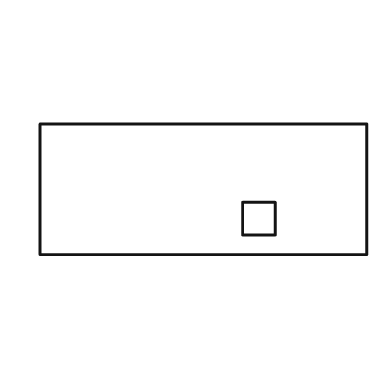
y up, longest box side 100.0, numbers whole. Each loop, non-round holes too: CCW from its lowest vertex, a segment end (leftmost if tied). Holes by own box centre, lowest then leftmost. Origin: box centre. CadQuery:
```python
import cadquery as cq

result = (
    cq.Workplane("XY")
    .moveTo(-50.0, -20.0)
    .lineTo(50.0, -20.0)
    .lineTo(50.0, 20.0)
    .lineTo(-50.0, 20.0)
    .close()
    .moveTo(12.0, -14.0)
    .lineTo(22.0, -14.0)
    .lineTo(22.0, -4.0)
    .lineTo(12.0, -4.0)
    .close()
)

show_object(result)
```